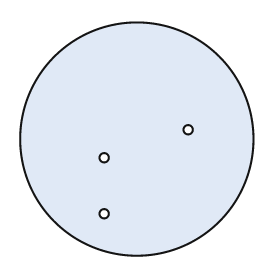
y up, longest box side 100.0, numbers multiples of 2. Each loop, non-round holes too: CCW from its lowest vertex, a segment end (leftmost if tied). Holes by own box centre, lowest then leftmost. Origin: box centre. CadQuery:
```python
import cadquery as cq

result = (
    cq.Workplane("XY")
    .moveTo(0.0, 0.0)
    .circle(50.0)
    .moveTo(-14.0, -32.0)
    .circle(2.0)
    .moveTo(-14.0, -8.0)
    .circle(2.0)
    .moveTo(22.0, 4.0)
    .circle(2.0)
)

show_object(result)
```